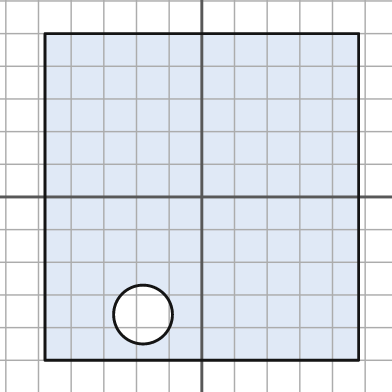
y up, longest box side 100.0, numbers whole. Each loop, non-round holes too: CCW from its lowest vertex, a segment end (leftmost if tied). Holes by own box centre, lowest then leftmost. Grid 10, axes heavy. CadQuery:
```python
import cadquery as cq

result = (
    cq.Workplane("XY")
    .moveTo(-48.0, -50.0)
    .lineTo(48.0, -50.0)
    .lineTo(48.0, 50.0)
    .lineTo(-48.0, 50.0)
    .close()
    .moveTo(-18.0, -36.0)
    .circle(9.0)
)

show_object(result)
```